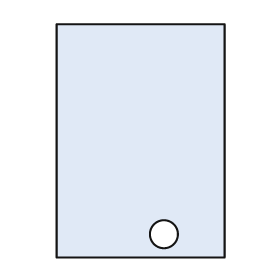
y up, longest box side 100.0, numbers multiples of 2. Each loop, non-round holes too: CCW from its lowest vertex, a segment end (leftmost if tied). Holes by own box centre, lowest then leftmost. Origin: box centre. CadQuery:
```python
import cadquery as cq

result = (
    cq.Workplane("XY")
    .moveTo(-36.0, -50.0)
    .lineTo(36.0, -50.0)
    .lineTo(36.0, 50.0)
    .lineTo(-36.0, 50.0)
    .close()
    .moveTo(10.0, -40.0)
    .circle(6.0)
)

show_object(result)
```